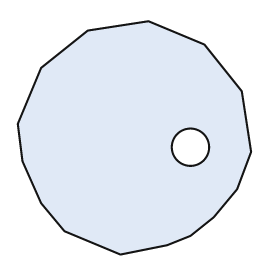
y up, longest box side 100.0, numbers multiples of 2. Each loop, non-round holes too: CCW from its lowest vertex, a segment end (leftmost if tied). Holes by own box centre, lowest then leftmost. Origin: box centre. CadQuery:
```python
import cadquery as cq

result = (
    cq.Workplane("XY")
    .moveTo(-6.0, -50.0)
    .lineTo(14.0, -46.0)
    .lineTo(24.0, -42.0)
    .lineTo(34.0, -34.0)
    .lineTo(44.0, -22.0)
    .lineTo(50.0, -6.0)
    .lineTo(46.0, 20.0)
    .lineTo(30.0, 40.0)
    .lineTo(6.0, 50.0)
    .lineTo(-20.0, 46.0)
    .lineTo(-40.0, 30.0)
    .lineTo(-50.0, 6.0)
    .lineTo(-48.0, -10.0)
    .lineTo(-40.0, -28.0)
    .lineTo(-30.0, -40.0)
    .close()
    .moveTo(24.0, -4.0)
    .circle(8.0)
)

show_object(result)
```